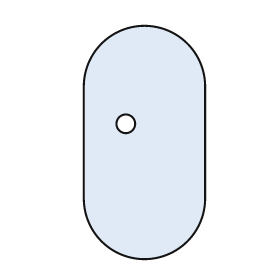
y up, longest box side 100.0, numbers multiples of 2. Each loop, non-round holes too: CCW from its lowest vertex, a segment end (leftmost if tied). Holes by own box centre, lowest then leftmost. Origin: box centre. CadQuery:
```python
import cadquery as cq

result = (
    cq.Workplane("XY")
    .moveTo(-26.0, -24.0)
    .threePointArc((0.0, -50.0), (26.0, -24.0))
    .lineTo(26.0, 24.0)
    .threePointArc((0.0, 50.0), (-26.0, 24.0))
    .close()
    .moveTo(-8.0, 8.0)
    .circle(4.0)
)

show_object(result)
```